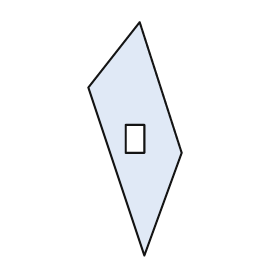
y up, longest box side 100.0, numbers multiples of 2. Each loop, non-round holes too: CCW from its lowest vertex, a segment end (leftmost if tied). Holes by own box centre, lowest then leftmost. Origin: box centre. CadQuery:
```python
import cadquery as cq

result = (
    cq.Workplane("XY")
    .moveTo(4.0, -50.0)
    .lineTo(20.0, -6.0)
    .lineTo(2.0, 50.0)
    .lineTo(-20.0, 22.0)
    .close()
    .moveTo(-4.0, -6.0)
    .lineTo(4.0, -6.0)
    .lineTo(4.0, 6.0)
    .lineTo(-4.0, 6.0)
    .close()
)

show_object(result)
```